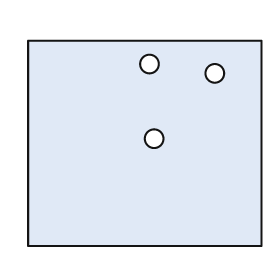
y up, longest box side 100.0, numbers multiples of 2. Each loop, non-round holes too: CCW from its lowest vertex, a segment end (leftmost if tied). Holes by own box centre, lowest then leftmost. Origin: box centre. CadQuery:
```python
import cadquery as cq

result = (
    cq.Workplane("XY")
    .moveTo(-50.0, -44.0)
    .lineTo(50.0, -44.0)
    .lineTo(50.0, 44.0)
    .lineTo(-50.0, 44.0)
    .close()
    .moveTo(4.0, 2.0)
    .circle(4.0)
    .moveTo(30.0, 30.0)
    .circle(4.0)
    .moveTo(2.0, 34.0)
    .circle(4.0)
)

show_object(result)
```